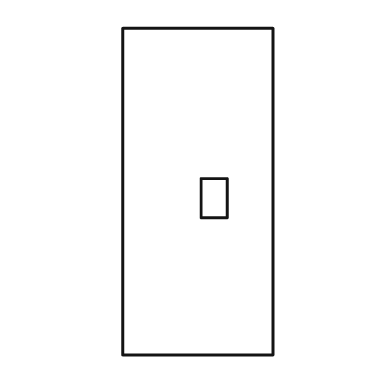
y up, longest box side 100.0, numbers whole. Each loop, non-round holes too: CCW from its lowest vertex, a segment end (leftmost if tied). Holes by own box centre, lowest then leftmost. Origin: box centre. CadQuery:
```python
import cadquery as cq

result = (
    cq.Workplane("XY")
    .moveTo(-23.0, -50.0)
    .lineTo(23.0, -50.0)
    .lineTo(23.0, 50.0)
    .lineTo(-23.0, 50.0)
    .close()
    .moveTo(1.0, -8.0)
    .lineTo(9.0, -8.0)
    .lineTo(9.0, 4.0)
    .lineTo(1.0, 4.0)
    .close()
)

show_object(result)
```